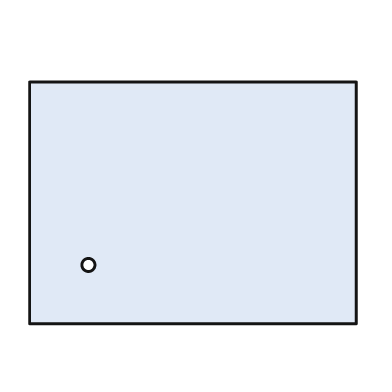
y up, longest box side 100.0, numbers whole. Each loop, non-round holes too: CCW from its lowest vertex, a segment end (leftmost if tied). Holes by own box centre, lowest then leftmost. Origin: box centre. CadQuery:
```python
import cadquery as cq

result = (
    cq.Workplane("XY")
    .moveTo(-50.0, -37.0)
    .lineTo(50.0, -37.0)
    .lineTo(50.0, 37.0)
    .lineTo(-50.0, 37.0)
    .close()
    .moveTo(-32.0, -19.0)
    .circle(2.0)
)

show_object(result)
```